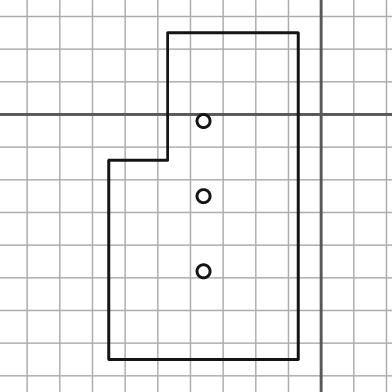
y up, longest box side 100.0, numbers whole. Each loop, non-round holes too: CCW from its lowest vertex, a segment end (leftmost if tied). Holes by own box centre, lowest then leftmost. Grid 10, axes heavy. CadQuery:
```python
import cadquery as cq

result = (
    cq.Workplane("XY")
    .moveTo(-65.0, -75.0)
    .lineTo(-7.0, -75.0)
    .lineTo(-7.0, 25.0)
    .lineTo(-47.0, 25.0)
    .lineTo(-47.0, -14.0)
    .lineTo(-65.0, -14.0)
    .close()
    .moveTo(-36.0, -48.0)
    .circle(2.0)
    .moveTo(-36.0, -25.0)
    .circle(2.0)
    .moveTo(-36.0, -2.0)
    .circle(2.0)
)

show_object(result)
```